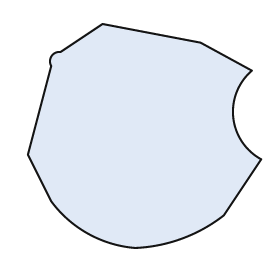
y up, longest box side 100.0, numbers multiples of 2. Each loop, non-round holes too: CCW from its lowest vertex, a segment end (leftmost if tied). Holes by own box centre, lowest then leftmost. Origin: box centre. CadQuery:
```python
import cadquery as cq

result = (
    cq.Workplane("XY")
    .moveTo(-4.0, -48.0)
    .threePointArc((16.0, -44.0), (34.0, -34.0))
    .lineTo(50.0, -10.0)
    .threePointArc((38.0, 8.0), (46.0, 28.0))
    .lineTo(24.0, 40.0)
    .lineTo(-18.0, 48.0)
    .lineTo(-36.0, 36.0)
    .threePointArc((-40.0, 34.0), (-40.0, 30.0))
    .lineTo(-50.0, -8.0)
    .lineTo(-40.0, -28.0)
    .threePointArc((-24.0, -42.0), (-4.0, -48.0))
    .close()
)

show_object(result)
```